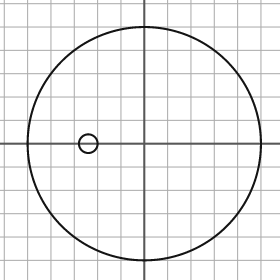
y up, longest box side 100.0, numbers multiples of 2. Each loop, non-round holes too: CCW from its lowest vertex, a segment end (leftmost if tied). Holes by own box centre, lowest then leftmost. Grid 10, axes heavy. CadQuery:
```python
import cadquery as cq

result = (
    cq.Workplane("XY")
    .moveTo(0.0, 0.0)
    .circle(50.0)
    .moveTo(-24.0, 0.0)
    .circle(4.0)
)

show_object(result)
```